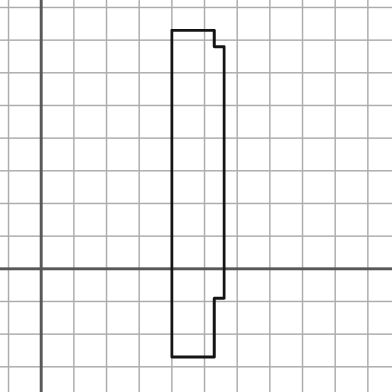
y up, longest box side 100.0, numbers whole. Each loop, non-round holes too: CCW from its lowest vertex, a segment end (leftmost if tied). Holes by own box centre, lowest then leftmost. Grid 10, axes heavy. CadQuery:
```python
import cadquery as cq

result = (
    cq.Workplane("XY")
    .moveTo(40.0, -27.0)
    .lineTo(53.0, -27.0)
    .lineTo(53.0, -9.0)
    .lineTo(56.0, -9.0)
    .lineTo(56.0, 68.0)
    .lineTo(53.0, 68.0)
    .lineTo(53.0, 73.0)
    .lineTo(40.0, 73.0)
    .close()
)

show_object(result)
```